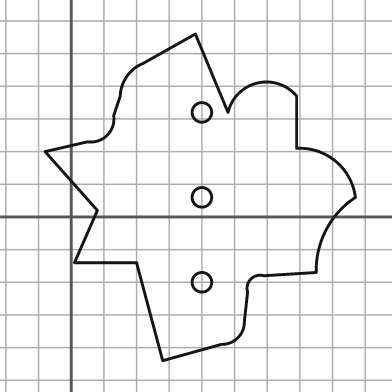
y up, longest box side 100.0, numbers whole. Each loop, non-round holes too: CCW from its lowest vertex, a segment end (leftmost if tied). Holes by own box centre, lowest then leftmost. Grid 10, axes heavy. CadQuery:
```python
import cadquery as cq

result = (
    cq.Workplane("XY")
    .moveTo(28.0, -44.0)
    .lineTo(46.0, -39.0)
    .threePointArc((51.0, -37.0), (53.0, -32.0))
    .lineTo(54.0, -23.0)
    .threePointArc((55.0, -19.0), (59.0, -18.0))
    .lineTo(75.0, -17.0)
    .threePointArc((78.0, -4.0), (87.0, 6.0))
    .threePointArc((81.0, 17.0), (69.0, 21.0))
    .lineTo(69.0, 37.0)
    .threePointArc((57.0, 41.0), (48.0, 32.0))
    .lineTo(38.0, 56.0)
    .lineTo(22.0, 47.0)
    .threePointArc((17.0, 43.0), (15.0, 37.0))
    .lineTo(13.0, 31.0)
    .threePointArc((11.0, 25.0), (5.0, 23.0))
    .lineTo(-8.0, 20.0)
    .lineTo(8.0, 2.0)
    .lineTo(1.0, -14.0)
    .lineTo(20.0, -14.0)
    .close()
    .moveTo(40.0, -20.0)
    .circle(3.0)
    .moveTo(40.0, 6.0)
    .circle(3.0)
    .moveTo(40.0, 32.0)
    .circle(3.0)
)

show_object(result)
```